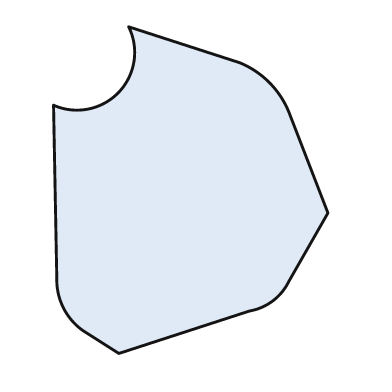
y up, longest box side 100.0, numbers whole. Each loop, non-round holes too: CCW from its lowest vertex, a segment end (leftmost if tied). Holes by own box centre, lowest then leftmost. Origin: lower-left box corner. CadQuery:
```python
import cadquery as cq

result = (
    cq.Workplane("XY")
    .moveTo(20.0, 0.0)
    .lineTo(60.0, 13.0)
    .threePointArc((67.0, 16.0), (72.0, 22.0))
    .lineTo(84.0, 43.0)
    .lineTo(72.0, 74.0)
    .threePointArc((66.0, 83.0), (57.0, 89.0))
    .lineTo(23.0, 100.0)
    .threePointArc((20.0, 80.0), (0.0, 76.0))
    .lineTo(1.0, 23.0)
    .threePointArc((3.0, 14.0), (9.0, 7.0))
    .close()
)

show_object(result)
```